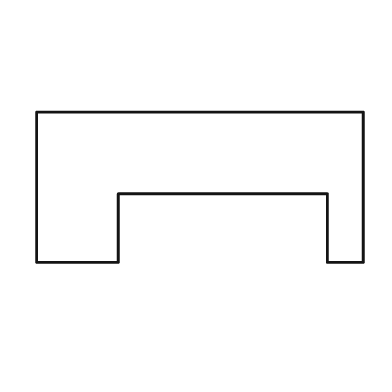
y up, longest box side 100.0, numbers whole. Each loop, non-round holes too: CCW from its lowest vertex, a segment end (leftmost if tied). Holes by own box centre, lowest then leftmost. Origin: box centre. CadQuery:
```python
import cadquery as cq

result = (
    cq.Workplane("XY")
    .moveTo(-50.0, -23.0)
    .lineTo(-25.0, -23.0)
    .lineTo(-25.0, -2.0)
    .lineTo(39.0, -2.0)
    .lineTo(39.0, -23.0)
    .lineTo(50.0, -23.0)
    .lineTo(50.0, 23.0)
    .lineTo(-50.0, 23.0)
    .close()
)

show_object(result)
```